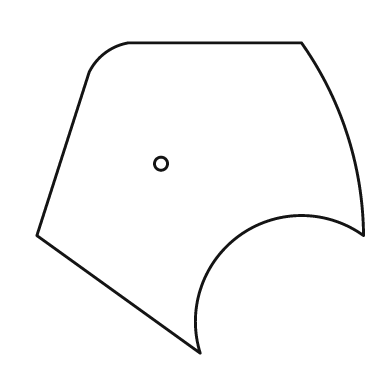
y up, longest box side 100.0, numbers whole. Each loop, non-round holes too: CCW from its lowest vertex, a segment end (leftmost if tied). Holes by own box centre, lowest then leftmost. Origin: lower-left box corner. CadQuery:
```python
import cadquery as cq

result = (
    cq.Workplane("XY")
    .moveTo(50.0, 0.0)
    .threePointArc((62.0, 36.0), (100.0, 36.0))
    .threePointArc((95.0, 67.0), (81.0, 95.0))
    .lineTo(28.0, 95.0)
    .threePointArc((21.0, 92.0), (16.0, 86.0))
    .lineTo(0.0, 36.0)
    .close()
    .moveTo(38.0, 58.0)
    .circle(2.0)
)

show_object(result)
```